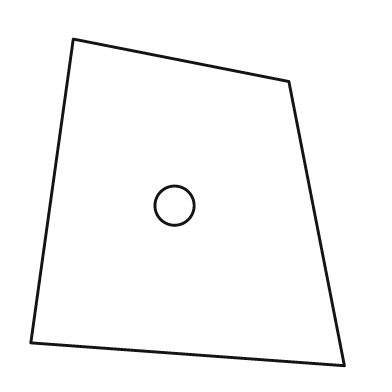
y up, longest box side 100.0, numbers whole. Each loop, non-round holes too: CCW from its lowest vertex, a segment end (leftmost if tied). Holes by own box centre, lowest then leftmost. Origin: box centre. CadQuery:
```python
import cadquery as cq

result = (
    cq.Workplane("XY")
    .moveTo(48.0, -50.0)
    .lineTo(31.0, 37.0)
    .lineTo(-35.0, 50.0)
    .lineTo(-48.0, -43.0)
    .close()
    .moveTo(-4.0, -1.0)
    .circle(6.0)
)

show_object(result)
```